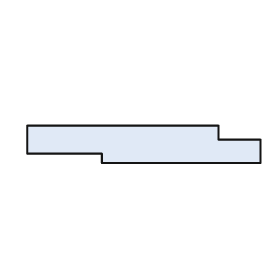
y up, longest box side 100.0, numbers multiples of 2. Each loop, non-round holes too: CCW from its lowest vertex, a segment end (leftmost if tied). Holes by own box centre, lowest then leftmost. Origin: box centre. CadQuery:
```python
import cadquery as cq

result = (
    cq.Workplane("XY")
    .moveTo(-18.0, -8.0)
    .lineTo(50.0, -8.0)
    .lineTo(50.0, 2.0)
    .lineTo(32.0, 2.0)
    .lineTo(32.0, 8.0)
    .lineTo(-50.0, 8.0)
    .lineTo(-50.0, -4.0)
    .lineTo(-18.0, -4.0)
    .close()
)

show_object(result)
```